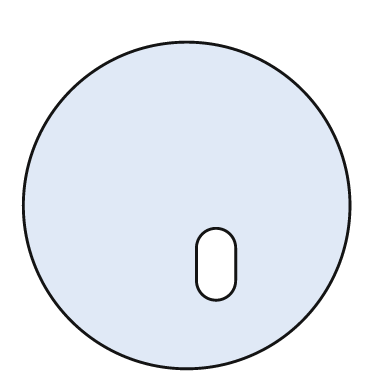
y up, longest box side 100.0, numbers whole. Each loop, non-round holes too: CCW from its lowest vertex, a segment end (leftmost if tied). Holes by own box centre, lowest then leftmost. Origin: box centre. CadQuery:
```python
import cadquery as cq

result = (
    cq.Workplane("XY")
    .moveTo(0.0, 0.0)
    .circle(50.0)
    .moveTo(3.0, -23.0)
    .threePointArc((9.0, -29.0), (15.0, -23.0))
    .lineTo(15.0, -13.0)
    .threePointArc((9.0, -7.0), (3.0, -13.0))
    .close()
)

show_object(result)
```